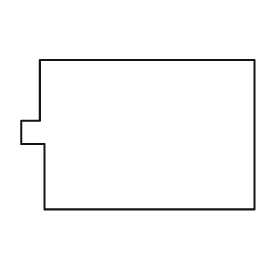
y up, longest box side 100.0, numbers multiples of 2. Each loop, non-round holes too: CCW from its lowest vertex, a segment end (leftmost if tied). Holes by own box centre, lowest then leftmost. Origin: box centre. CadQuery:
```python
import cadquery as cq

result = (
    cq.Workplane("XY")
    .moveTo(-40.0, -32.0)
    .lineTo(50.0, -32.0)
    .lineTo(50.0, 32.0)
    .lineTo(-42.0, 32.0)
    .lineTo(-42.0, 6.0)
    .lineTo(-50.0, 6.0)
    .lineTo(-50.0, -4.0)
    .lineTo(-40.0, -4.0)
    .close()
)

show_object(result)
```